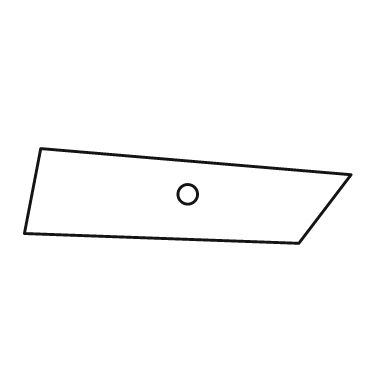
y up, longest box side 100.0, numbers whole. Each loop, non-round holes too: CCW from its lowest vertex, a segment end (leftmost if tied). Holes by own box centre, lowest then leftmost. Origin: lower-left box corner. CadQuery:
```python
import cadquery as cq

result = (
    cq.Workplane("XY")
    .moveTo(84.0, 0.0)
    .lineTo(100.0, 21.0)
    .lineTo(5.0, 29.0)
    .lineTo(0.0, 3.0)
    .close()
    .moveTo(50.0, 15.0)
    .circle(3.0)
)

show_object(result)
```